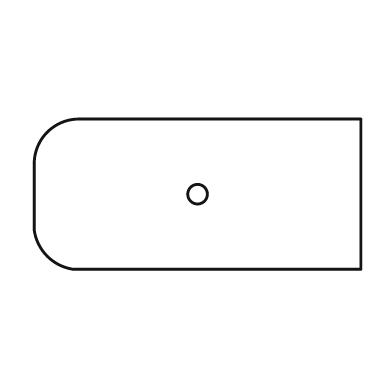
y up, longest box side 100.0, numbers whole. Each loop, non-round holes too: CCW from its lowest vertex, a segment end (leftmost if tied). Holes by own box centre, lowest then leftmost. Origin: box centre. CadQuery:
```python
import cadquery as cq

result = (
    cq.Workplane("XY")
    .moveTo(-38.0, -23.0)
    .lineTo(50.0, -23.0)
    .lineTo(50.0, 23.0)
    .lineTo(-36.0, 23.0)
    .threePointArc((-46.0, 19.0), (-50.0, 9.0))
    .lineTo(-50.0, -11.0)
    .threePointArc((-46.0, -19.0), (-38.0, -23.0))
    .close()
    .moveTo(0.0, 0.0)
    .circle(3.0)
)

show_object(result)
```